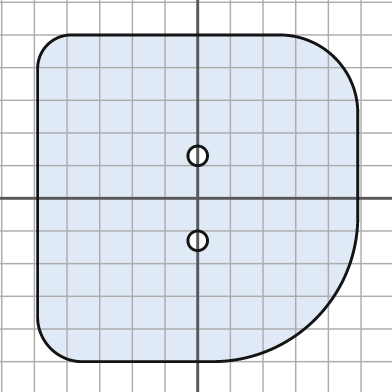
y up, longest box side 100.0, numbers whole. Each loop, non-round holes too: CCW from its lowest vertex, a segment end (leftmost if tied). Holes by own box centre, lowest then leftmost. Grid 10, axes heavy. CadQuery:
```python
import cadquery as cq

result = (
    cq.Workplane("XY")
    .moveTo(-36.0, -50.0)
    .lineTo(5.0, -50.0)
    .threePointArc((36.0, -37.0), (49.0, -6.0))
    .lineTo(49.0, 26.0)
    .threePointArc((42.0, 43.0), (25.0, 50.0))
    .lineTo(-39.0, 50.0)
    .threePointArc((-46.0, 47.0), (-49.0, 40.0))
    .lineTo(-49.0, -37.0)
    .threePointArc((-45.0, -46.0), (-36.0, -50.0))
    .close()
    .moveTo(0.0, -13.0)
    .circle(3.0)
    .moveTo(0.0, 13.0)
    .circle(3.0)
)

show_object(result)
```